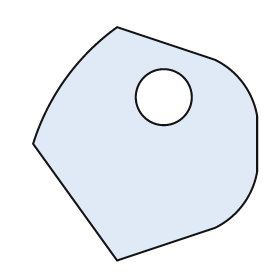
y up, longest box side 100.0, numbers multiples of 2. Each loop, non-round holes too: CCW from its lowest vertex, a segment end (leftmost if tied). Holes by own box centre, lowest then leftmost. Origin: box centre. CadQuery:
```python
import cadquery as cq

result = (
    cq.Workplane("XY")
    .moveTo(-12.0, -50.0)
    .lineTo(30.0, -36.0)
    .threePointArc((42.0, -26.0), (48.0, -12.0))
    .lineTo(48.0, 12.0)
    .threePointArc((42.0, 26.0), (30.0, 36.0))
    .lineTo(-12.0, 50.0)
    .threePointArc((-34.0, 28.0), (-48.0, 0.0))
    .close()
    .moveTo(8.0, 20.0)
    .circle(12.0)
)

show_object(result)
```